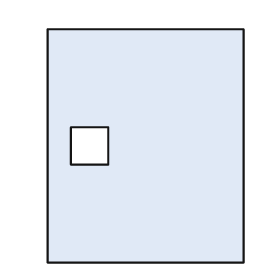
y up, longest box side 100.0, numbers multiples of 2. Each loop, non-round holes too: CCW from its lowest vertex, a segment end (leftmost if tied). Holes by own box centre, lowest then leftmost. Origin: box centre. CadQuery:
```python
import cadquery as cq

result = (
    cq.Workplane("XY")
    .moveTo(-42.0, -50.0)
    .lineTo(42.0, -50.0)
    .lineTo(42.0, 50.0)
    .lineTo(-42.0, 50.0)
    .close()
    .moveTo(-32.0, -8.0)
    .lineTo(-16.0, -8.0)
    .lineTo(-16.0, 8.0)
    .lineTo(-32.0, 8.0)
    .close()
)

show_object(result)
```